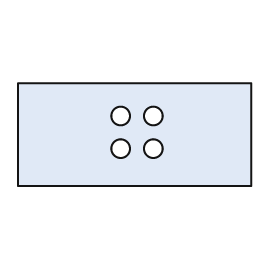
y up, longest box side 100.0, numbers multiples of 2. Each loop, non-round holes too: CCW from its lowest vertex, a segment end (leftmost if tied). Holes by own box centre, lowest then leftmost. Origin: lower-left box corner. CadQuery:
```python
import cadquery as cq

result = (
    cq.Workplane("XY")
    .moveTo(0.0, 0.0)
    .lineTo(100.0, 0.0)
    .lineTo(100.0, 44.0)
    .lineTo(0.0, 44.0)
    .close()
    .moveTo(44.0, 16.0)
    .circle(4.0)
    .moveTo(58.0, 16.0)
    .circle(4.0)
    .moveTo(44.0, 30.0)
    .circle(4.0)
    .moveTo(58.0, 30.0)
    .circle(4.0)
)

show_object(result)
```